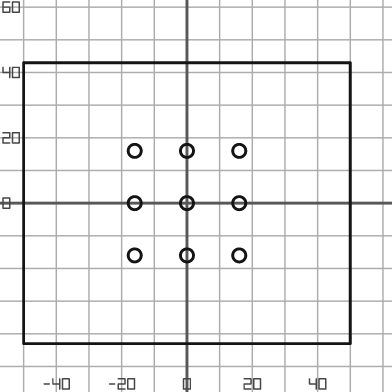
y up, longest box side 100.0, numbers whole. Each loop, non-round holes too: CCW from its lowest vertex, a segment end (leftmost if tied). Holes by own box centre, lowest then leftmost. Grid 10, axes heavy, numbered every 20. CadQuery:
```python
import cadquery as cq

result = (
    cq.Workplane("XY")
    .moveTo(-50.0, -43.0)
    .lineTo(50.0, -43.0)
    .lineTo(50.0, 43.0)
    .lineTo(-50.0, 43.0)
    .close()
    .moveTo(-16.0, -16.0)
    .circle(2.0)
    .moveTo(0.0, -16.0)
    .circle(2.0)
    .moveTo(16.0, -16.0)
    .circle(2.0)
    .moveTo(-16.0, 0.0)
    .circle(2.0)
    .moveTo(0.0, 0.0)
    .circle(2.0)
    .moveTo(16.0, 0.0)
    .circle(2.0)
    .moveTo(-16.0, 16.0)
    .circle(2.0)
    .moveTo(0.0, 16.0)
    .circle(2.0)
    .moveTo(16.0, 16.0)
    .circle(2.0)
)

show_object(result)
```